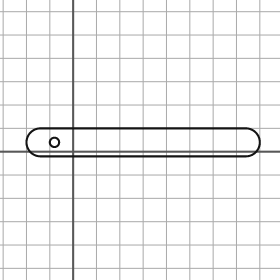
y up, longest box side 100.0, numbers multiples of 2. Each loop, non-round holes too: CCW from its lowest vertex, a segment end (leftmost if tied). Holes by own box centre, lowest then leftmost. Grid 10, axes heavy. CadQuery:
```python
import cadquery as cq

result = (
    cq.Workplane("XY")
    .moveTo(-14.0, -2.0)
    .lineTo(74.0, -2.0)
    .threePointArc((80.0, 4.0), (74.0, 10.0))
    .lineTo(-14.0, 10.0)
    .threePointArc((-20.0, 4.0), (-14.0, -2.0))
    .close()
    .moveTo(-8.0, 4.0)
    .circle(2.0)
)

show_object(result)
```